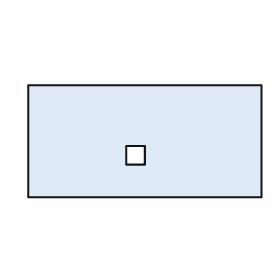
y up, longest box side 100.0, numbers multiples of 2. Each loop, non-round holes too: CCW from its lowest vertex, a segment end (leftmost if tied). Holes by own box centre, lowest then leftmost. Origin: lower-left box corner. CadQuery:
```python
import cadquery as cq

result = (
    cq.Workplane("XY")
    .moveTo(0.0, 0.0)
    .lineTo(100.0, 0.0)
    .lineTo(100.0, 48.0)
    .lineTo(0.0, 48.0)
    .close()
    .moveTo(42.0, 14.0)
    .lineTo(50.0, 14.0)
    .lineTo(50.0, 22.0)
    .lineTo(42.0, 22.0)
    .close()
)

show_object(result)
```